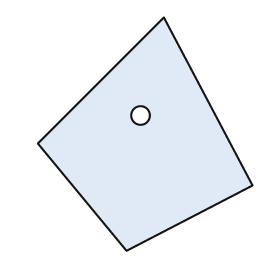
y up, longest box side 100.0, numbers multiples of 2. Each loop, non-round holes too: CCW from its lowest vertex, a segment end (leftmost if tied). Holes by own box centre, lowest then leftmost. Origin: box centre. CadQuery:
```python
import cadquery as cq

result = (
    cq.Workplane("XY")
    .moveTo(-8.0, -50.0)
    .lineTo(46.0, -22.0)
    .lineTo(8.0, 50.0)
    .lineTo(-46.0, -4.0)
    .close()
    .moveTo(-2.0, 8.0)
    .circle(4.0)
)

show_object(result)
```